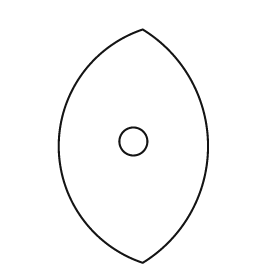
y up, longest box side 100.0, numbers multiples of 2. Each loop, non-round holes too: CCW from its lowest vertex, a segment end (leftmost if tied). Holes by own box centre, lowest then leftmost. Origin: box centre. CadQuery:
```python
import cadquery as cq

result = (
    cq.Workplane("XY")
    .moveTo(4.0, -50.0)
    .threePointArc((32.0, 0.0), (4.0, 50.0))
    .threePointArc((-32.0, 0.0), (4.0, -50.0))
    .close()
    .moveTo(0.0, 2.0)
    .circle(6.0)
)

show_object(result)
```